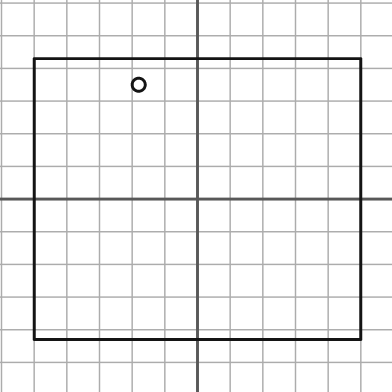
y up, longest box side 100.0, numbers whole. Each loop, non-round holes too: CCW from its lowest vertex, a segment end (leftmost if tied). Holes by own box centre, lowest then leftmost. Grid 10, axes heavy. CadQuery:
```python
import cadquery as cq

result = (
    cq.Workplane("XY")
    .moveTo(-50.0, -43.0)
    .lineTo(50.0, -43.0)
    .lineTo(50.0, 43.0)
    .lineTo(-50.0, 43.0)
    .close()
    .moveTo(-18.0, 35.0)
    .circle(2.0)
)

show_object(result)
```